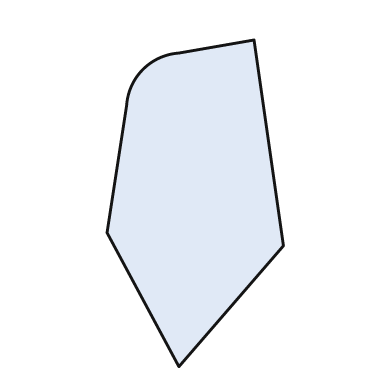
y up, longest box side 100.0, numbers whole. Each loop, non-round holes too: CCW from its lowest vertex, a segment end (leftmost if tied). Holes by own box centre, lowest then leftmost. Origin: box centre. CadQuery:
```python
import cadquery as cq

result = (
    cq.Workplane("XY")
    .moveTo(-5.0, -50.0)
    .lineTo(27.0, -13.0)
    .lineTo(18.0, 50.0)
    .lineTo(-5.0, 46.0)
    .threePointArc((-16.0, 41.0), (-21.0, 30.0))
    .lineTo(-27.0, -9.0)
    .close()
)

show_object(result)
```